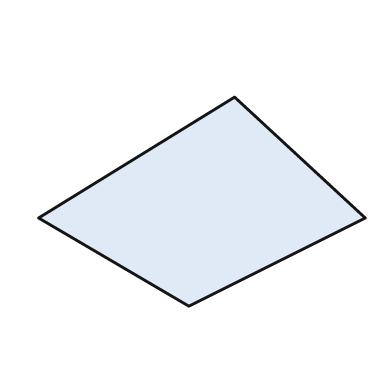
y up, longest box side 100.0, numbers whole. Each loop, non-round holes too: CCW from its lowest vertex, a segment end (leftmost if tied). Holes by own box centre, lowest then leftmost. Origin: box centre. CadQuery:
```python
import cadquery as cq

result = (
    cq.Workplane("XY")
    .moveTo(-4.0, -32.0)
    .lineTo(50.0, -5.0)
    .lineTo(10.0, 32.0)
    .lineTo(-50.0, -5.0)
    .close()
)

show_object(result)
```